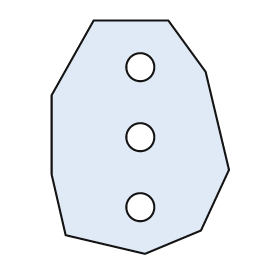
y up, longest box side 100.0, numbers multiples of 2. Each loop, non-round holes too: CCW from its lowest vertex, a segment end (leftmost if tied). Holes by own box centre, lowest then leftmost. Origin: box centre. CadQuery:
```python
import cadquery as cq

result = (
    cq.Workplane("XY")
    .moveTo(2.0, -50.0)
    .lineTo(26.0, -40.0)
    .lineTo(38.0, -14.0)
    .lineTo(28.0, 28.0)
    .lineTo(12.0, 50.0)
    .lineTo(-20.0, 50.0)
    .lineTo(-38.0, 18.0)
    .lineTo(-38.0, -16.0)
    .lineTo(-32.0, -42.0)
    .close()
    .moveTo(0.0, -30.0)
    .circle(6.0)
    .moveTo(0.0, 0.0)
    .circle(6.0)
    .moveTo(0.0, 30.0)
    .circle(6.0)
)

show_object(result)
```